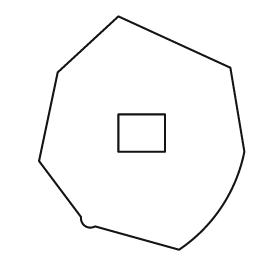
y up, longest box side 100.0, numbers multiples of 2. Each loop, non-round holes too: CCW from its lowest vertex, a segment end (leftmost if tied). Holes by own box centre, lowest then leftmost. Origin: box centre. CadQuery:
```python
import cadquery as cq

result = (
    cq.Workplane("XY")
    .moveTo(16.0, -50.0)
    .threePointArc((34.0, -32.0), (44.0, -8.0))
    .lineTo(38.0, 28.0)
    .lineTo(-10.0, 50.0)
    .lineTo(-36.0, 26.0)
    .lineTo(-44.0, -12.0)
    .lineTo(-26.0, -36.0)
    .threePointArc((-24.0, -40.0), (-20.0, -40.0))
    .close()
    .moveTo(-10.0, -8.0)
    .lineTo(10.0, -8.0)
    .lineTo(10.0, 8.0)
    .lineTo(-10.0, 8.0)
    .close()
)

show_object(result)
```